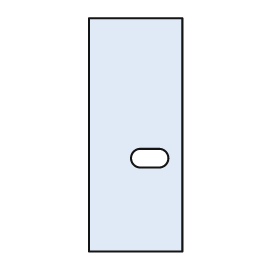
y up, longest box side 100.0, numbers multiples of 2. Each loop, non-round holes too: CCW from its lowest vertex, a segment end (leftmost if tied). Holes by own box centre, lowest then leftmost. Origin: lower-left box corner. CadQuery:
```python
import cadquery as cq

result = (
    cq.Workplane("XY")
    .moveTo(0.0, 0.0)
    .lineTo(40.0, 0.0)
    .lineTo(40.0, 100.0)
    .lineTo(0.0, 100.0)
    .close()
    .moveTo(22.0, 36.0)
    .lineTo(30.0, 36.0)
    .threePointArc((34.0, 40.0), (30.0, 44.0))
    .lineTo(22.0, 44.0)
    .threePointArc((18.0, 40.0), (22.0, 36.0))
    .close()
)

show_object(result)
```